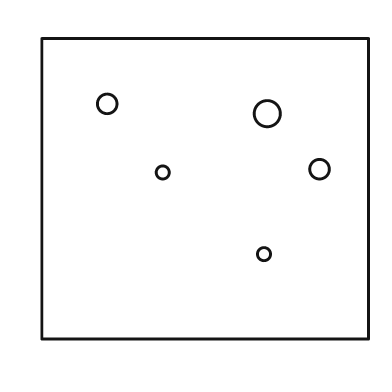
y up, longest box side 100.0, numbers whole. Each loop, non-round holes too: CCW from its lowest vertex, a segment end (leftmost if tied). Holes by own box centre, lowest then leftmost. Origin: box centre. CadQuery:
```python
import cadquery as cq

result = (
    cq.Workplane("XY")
    .moveTo(-50.0, -46.0)
    .lineTo(50.0, -46.0)
    .lineTo(50.0, 46.0)
    .lineTo(-50.0, 46.0)
    .close()
    .moveTo(18.0, -20.0)
    .circle(2.0)
    .moveTo(-13.0, 5.0)
    .circle(2.0)
    .moveTo(35.0, 6.0)
    .circle(3.0)
    .moveTo(19.0, 23.0)
    .circle(4.0)
    .moveTo(-30.0, 26.0)
    .circle(3.0)
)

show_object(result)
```